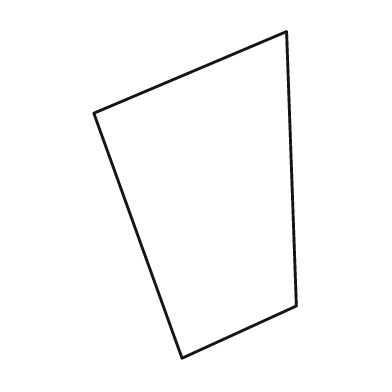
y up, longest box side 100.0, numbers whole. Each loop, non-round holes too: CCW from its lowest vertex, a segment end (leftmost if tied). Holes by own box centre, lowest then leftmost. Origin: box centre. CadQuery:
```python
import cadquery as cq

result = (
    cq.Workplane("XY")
    .moveTo(-4.0, -50.0)
    .lineTo(31.0, -34.0)
    .lineTo(28.0, 50.0)
    .lineTo(-31.0, 25.0)
    .close()
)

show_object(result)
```